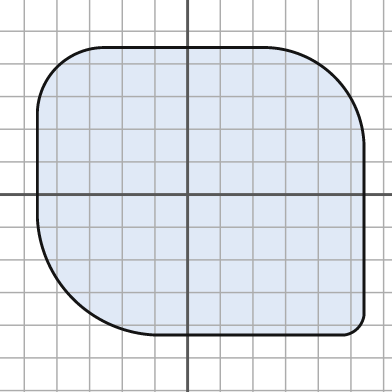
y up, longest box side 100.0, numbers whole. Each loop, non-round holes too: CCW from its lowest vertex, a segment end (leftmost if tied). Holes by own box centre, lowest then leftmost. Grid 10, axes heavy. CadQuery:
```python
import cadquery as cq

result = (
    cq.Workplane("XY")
    .moveTo(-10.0, -43.0)
    .lineTo(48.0, -43.0)
    .threePointArc((52.0, -41.0), (54.0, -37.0))
    .lineTo(54.0, 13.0)
    .threePointArc((45.0, 36.0), (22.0, 45.0))
    .lineTo(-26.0, 45.0)
    .threePointArc((-40.0, 39.0), (-46.0, 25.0))
    .lineTo(-46.0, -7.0)
    .threePointArc((-35.0, -32.0), (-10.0, -43.0))
    .close()
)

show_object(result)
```